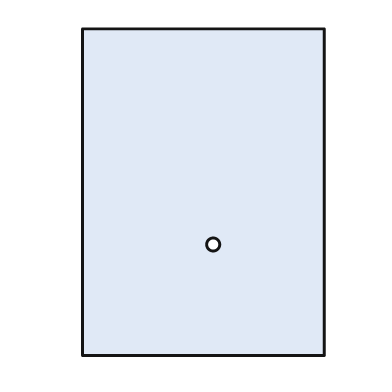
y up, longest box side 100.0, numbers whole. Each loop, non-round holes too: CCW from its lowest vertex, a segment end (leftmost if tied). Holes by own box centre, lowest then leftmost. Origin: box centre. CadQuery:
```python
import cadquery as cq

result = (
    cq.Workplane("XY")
    .moveTo(-37.0, -50.0)
    .lineTo(37.0, -50.0)
    .lineTo(37.0, 50.0)
    .lineTo(-37.0, 50.0)
    .close()
    .moveTo(3.0, -16.0)
    .circle(2.0)
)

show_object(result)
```